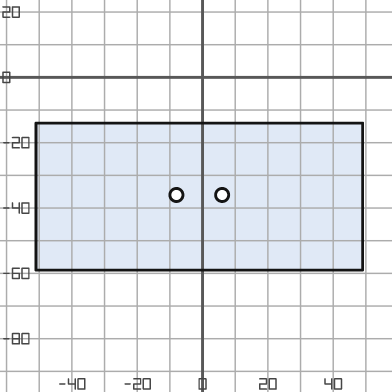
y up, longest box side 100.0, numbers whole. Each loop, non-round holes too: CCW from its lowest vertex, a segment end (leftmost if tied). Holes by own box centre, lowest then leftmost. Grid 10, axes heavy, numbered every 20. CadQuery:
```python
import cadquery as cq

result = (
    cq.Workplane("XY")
    .moveTo(-51.0, -59.0)
    .lineTo(49.0, -59.0)
    .lineTo(49.0, -14.0)
    .lineTo(-51.0, -14.0)
    .close()
    .moveTo(-8.0, -36.0)
    .circle(2.0)
    .moveTo(6.0, -36.0)
    .circle(2.0)
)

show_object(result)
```